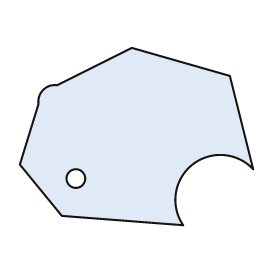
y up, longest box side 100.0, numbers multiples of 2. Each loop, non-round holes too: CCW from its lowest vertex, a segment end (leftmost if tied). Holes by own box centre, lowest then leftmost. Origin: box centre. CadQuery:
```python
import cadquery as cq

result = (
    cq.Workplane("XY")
    .moveTo(20.0, -38.0)
    .threePointArc((24.0, -12.0), (50.0, -14.0))
    .lineTo(40.0, 26.0)
    .lineTo(-2.0, 38.0)
    .lineTo(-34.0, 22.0)
    .threePointArc((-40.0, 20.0), (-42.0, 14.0))
    .lineTo(-50.0, -12.0)
    .lineTo(-32.0, -34.0)
    .close()
    .moveTo(-26.0, -18.0)
    .circle(4.0)
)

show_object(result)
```